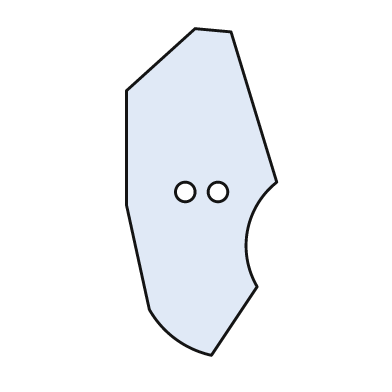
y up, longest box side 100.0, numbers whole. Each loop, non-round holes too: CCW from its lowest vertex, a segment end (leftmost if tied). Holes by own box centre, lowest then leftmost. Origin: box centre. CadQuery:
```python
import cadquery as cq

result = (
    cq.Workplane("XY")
    .moveTo(3.0, -50.0)
    .lineTo(17.0, -29.0)
    .threePointArc((14.0, -12.0), (23.0, 3.0))
    .lineTo(9.0, 49.0)
    .lineTo(-2.0, 50.0)
    .lineTo(-23.0, 31.0)
    .lineTo(-23.0, -4.0)
    .lineTo(-16.0, -36.0)
    .threePointArc((-8.0, -45.0), (3.0, -50.0))
    .close()
    .moveTo(-5.0, 0.0)
    .circle(3.0)
    .moveTo(5.0, 0.0)
    .circle(3.0)
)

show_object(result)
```